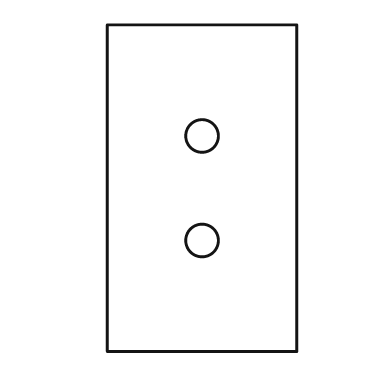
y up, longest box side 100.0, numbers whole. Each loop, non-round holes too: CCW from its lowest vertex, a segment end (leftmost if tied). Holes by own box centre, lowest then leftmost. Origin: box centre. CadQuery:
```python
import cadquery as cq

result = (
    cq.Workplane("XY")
    .moveTo(-29.0, -50.0)
    .lineTo(29.0, -50.0)
    .lineTo(29.0, 50.0)
    .lineTo(-29.0, 50.0)
    .close()
    .moveTo(0.0, -16.0)
    .circle(5.0)
    .moveTo(0.0, 16.0)
    .circle(5.0)
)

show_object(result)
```